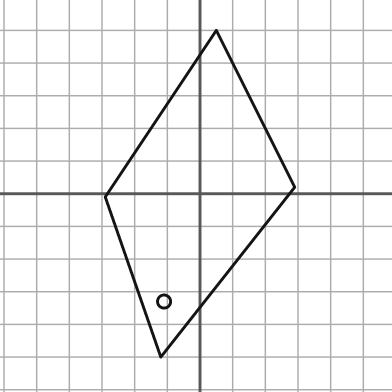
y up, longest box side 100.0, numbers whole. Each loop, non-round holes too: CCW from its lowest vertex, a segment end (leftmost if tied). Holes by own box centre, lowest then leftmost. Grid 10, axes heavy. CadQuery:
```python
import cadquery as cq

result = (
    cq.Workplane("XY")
    .moveTo(-12.0, -50.0)
    .lineTo(29.0, 2.0)
    .lineTo(5.0, 50.0)
    .lineTo(-29.0, -1.0)
    .close()
    .moveTo(-11.0, -33.0)
    .circle(2.0)
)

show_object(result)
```